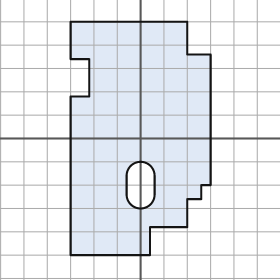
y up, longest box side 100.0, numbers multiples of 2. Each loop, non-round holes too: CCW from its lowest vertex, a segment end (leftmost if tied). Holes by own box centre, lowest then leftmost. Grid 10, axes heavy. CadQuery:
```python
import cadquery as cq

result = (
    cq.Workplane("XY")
    .moveTo(-30.0, -50.0)
    .lineTo(4.0, -50.0)
    .lineTo(4.0, -38.0)
    .lineTo(20.0, -38.0)
    .lineTo(20.0, -26.0)
    .lineTo(26.0, -26.0)
    .lineTo(26.0, -20.0)
    .lineTo(30.0, -20.0)
    .lineTo(30.0, 36.0)
    .lineTo(20.0, 36.0)
    .lineTo(20.0, 50.0)
    .lineTo(-30.0, 50.0)
    .lineTo(-30.0, 34.0)
    .lineTo(-22.0, 34.0)
    .lineTo(-22.0, 18.0)
    .lineTo(-30.0, 18.0)
    .close()
    .moveTo(-6.0, -24.0)
    .threePointArc((0.0, -30.0), (6.0, -24.0))
    .lineTo(6.0, -16.0)
    .threePointArc((0.0, -10.0), (-6.0, -16.0))
    .close()
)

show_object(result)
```